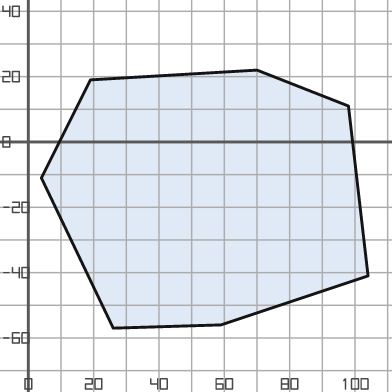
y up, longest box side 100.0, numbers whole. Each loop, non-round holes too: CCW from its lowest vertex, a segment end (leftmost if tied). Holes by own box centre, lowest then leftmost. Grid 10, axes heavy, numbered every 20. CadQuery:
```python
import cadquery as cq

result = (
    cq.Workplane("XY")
    .moveTo(26.0, -57.0)
    .lineTo(59.0, -56.0)
    .lineTo(104.0, -41.0)
    .lineTo(98.0, 11.0)
    .lineTo(70.0, 22.0)
    .lineTo(19.0, 19.0)
    .lineTo(4.0, -11.0)
    .close()
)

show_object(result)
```